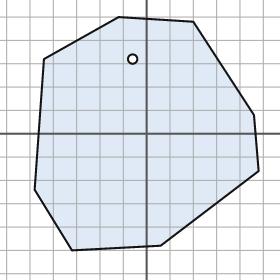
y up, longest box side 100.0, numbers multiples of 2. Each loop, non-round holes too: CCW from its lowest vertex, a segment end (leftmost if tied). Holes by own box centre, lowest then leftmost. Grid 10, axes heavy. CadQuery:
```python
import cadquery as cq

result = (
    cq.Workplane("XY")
    .moveTo(-32.0, -50.0)
    .lineTo(6.0, -48.0)
    .lineTo(48.0, -16.0)
    .lineTo(46.0, 8.0)
    .lineTo(20.0, 48.0)
    .lineTo(-12.0, 50.0)
    .lineTo(-44.0, 32.0)
    .lineTo(-48.0, -24.0)
    .close()
    .moveTo(-6.0, 32.0)
    .circle(2.0)
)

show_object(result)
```